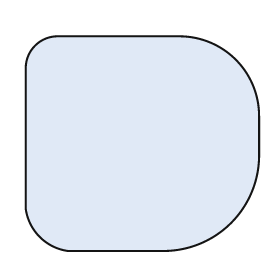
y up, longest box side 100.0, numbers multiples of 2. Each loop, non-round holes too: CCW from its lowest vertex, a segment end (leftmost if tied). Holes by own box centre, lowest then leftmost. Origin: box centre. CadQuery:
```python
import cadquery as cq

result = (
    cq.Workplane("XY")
    .moveTo(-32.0, -46.0)
    .lineTo(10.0, -46.0)
    .threePointArc((38.0, -34.0), (50.0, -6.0))
    .lineTo(50.0, 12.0)
    .threePointArc((40.0, 36.0), (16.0, 46.0))
    .lineTo(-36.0, 46.0)
    .threePointArc((-46.0, 42.0), (-50.0, 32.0))
    .lineTo(-50.0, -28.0)
    .threePointArc((-44.0, -40.0), (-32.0, -46.0))
    .close()
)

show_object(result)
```